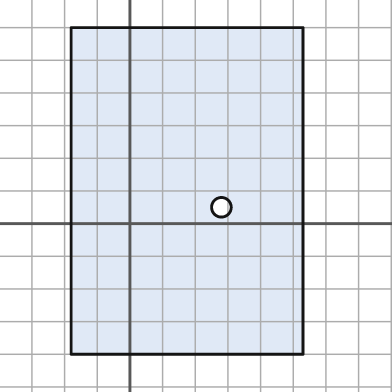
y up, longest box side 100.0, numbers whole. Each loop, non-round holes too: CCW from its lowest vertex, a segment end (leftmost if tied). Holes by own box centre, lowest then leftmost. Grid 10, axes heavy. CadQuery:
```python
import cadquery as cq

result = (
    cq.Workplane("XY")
    .moveTo(-18.0, -40.0)
    .lineTo(53.0, -40.0)
    .lineTo(53.0, 60.0)
    .lineTo(-18.0, 60.0)
    .close()
    .moveTo(28.0, 5.0)
    .circle(3.0)
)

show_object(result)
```